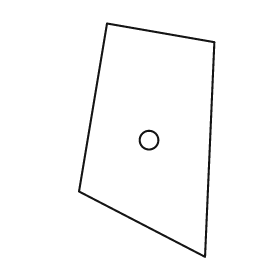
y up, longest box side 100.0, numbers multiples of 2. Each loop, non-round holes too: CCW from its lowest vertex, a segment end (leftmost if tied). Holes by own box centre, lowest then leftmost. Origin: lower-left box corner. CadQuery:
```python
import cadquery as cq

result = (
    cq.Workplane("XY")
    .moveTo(54.0, 0.0)
    .lineTo(58.0, 92.0)
    .lineTo(12.0, 100.0)
    .lineTo(0.0, 28.0)
    .close()
    .moveTo(30.0, 50.0)
    .circle(4.0)
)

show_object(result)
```